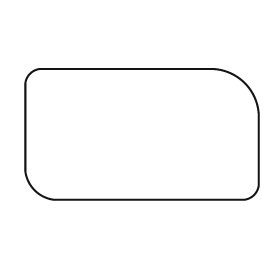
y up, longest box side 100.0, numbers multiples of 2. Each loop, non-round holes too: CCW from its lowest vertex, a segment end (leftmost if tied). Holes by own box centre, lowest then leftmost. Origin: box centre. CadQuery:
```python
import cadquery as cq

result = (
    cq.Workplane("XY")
    .moveTo(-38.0, -28.0)
    .lineTo(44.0, -28.0)
    .threePointArc((48.0, -26.0), (50.0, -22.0))
    .lineTo(50.0, 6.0)
    .threePointArc((44.0, 22.0), (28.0, 28.0))
    .lineTo(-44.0, 28.0)
    .threePointArc((-48.0, 26.0), (-50.0, 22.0))
    .lineTo(-50.0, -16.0)
    .threePointArc((-46.0, -24.0), (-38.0, -28.0))
    .close()
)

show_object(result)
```